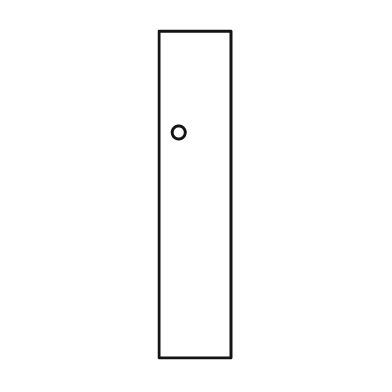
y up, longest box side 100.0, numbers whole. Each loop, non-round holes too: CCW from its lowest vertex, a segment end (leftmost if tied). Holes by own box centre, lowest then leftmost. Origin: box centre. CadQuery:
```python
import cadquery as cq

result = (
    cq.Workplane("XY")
    .moveTo(-11.0, -50.0)
    .lineTo(11.0, -50.0)
    .lineTo(11.0, 50.0)
    .lineTo(-11.0, 50.0)
    .close()
    .moveTo(-5.0, 19.0)
    .circle(2.0)
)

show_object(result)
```